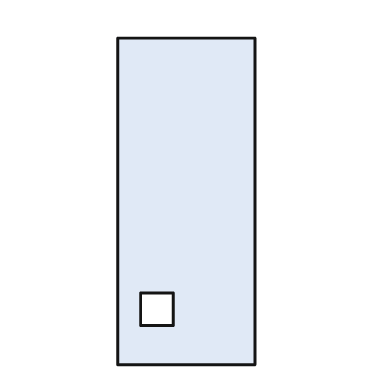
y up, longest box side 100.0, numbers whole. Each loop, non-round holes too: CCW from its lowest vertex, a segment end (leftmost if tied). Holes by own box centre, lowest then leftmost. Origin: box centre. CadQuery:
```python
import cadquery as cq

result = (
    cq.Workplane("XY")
    .moveTo(-21.0, -50.0)
    .lineTo(21.0, -50.0)
    .lineTo(21.0, 50.0)
    .lineTo(-21.0, 50.0)
    .close()
    .moveTo(-14.0, -38.0)
    .lineTo(-4.0, -38.0)
    .lineTo(-4.0, -28.0)
    .lineTo(-14.0, -28.0)
    .close()
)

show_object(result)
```